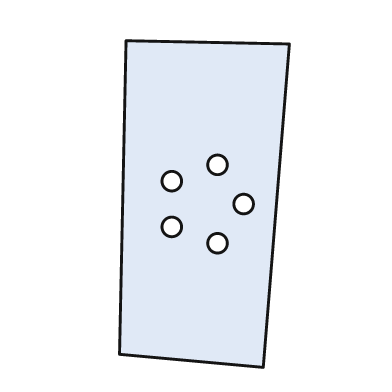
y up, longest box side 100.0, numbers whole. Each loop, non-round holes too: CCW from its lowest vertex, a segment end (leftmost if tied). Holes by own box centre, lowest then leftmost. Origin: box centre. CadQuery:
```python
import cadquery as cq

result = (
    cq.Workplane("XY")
    .moveTo(18.0, -50.0)
    .lineTo(26.0, 49.0)
    .lineTo(-24.0, 50.0)
    .lineTo(-26.0, -46.0)
    .close()
    .moveTo(4.0, -12.0)
    .circle(3.0)
    .moveTo(-10.0, -7.0)
    .circle(3.0)
    .moveTo(12.0, 0.0)
    .circle(3.0)
    .moveTo(-10.0, 7.0)
    .circle(3.0)
    .moveTo(4.0, 12.0)
    .circle(3.0)
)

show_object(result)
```